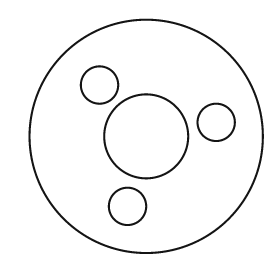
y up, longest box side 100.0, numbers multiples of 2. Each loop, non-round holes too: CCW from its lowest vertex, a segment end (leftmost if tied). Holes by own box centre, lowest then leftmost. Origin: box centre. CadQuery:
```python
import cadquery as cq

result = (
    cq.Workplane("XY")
    .moveTo(0.0, 0.0)
    .circle(50.0)
    .moveTo(-8.0, -30.0)
    .circle(8.0)
    .moveTo(0.0, 0.0)
    .circle(18.0)
    .moveTo(30.0, 6.0)
    .circle(8.0)
    .moveTo(-20.0, 22.0)
    .circle(8.0)
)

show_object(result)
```